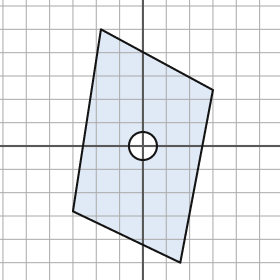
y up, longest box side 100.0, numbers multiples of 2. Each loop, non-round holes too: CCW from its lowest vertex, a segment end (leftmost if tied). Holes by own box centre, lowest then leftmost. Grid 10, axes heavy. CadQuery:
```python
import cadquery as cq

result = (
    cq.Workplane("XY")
    .moveTo(16.0, -50.0)
    .lineTo(30.0, 24.0)
    .lineTo(-18.0, 50.0)
    .lineTo(-30.0, -28.0)
    .close()
    .moveTo(0.0, 0.0)
    .circle(6.0)
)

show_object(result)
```